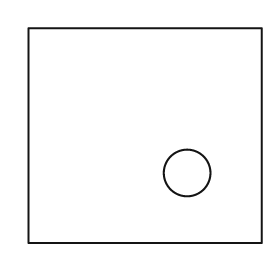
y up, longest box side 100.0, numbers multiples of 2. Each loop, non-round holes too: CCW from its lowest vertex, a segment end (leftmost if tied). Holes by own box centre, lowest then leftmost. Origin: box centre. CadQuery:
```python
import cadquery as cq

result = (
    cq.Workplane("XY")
    .moveTo(-50.0, -46.0)
    .lineTo(50.0, -46.0)
    .lineTo(50.0, 46.0)
    .lineTo(-50.0, 46.0)
    .close()
    .moveTo(18.0, -16.0)
    .circle(10.0)
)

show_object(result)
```